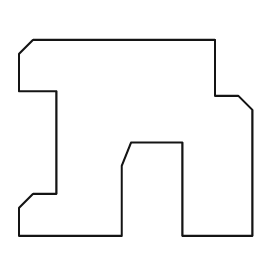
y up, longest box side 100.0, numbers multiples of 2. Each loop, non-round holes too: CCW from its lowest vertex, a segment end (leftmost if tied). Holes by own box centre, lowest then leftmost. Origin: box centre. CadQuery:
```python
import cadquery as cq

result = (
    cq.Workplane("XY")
    .moveTo(-50.0, -42.0)
    .lineTo(-6.0, -42.0)
    .lineTo(-6.0, -12.0)
    .lineTo(-2.0, -2.0)
    .lineTo(20.0, -2.0)
    .lineTo(20.0, -42.0)
    .lineTo(50.0, -42.0)
    .lineTo(50.0, 12.0)
    .lineTo(44.0, 18.0)
    .lineTo(34.0, 18.0)
    .lineTo(34.0, 42.0)
    .lineTo(-44.0, 42.0)
    .lineTo(-50.0, 36.0)
    .lineTo(-50.0, 20.0)
    .lineTo(-34.0, 20.0)
    .lineTo(-34.0, -24.0)
    .lineTo(-44.0, -24.0)
    .lineTo(-50.0, -30.0)
    .close()
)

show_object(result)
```